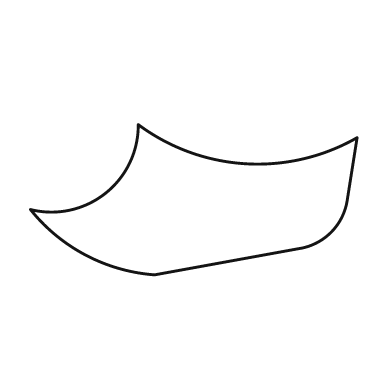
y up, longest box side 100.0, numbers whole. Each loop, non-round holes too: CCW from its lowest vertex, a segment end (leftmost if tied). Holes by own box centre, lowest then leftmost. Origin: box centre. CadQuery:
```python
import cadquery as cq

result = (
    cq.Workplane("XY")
    .moveTo(-12.0, -23.0)
    .lineTo(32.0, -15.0)
    .threePointArc((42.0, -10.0), (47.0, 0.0))
    .lineTo(50.0, 19.0)
    .threePointArc((16.0, 11.0), (-17.0, 23.0))
    .threePointArc((-27.0, 2.0), (-50.0, -3.0))
    .threePointArc((-33.0, -17.0), (-12.0, -23.0))
    .close()
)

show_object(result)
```